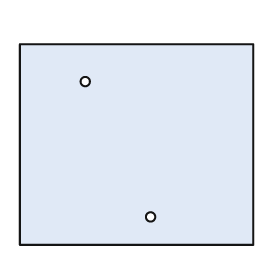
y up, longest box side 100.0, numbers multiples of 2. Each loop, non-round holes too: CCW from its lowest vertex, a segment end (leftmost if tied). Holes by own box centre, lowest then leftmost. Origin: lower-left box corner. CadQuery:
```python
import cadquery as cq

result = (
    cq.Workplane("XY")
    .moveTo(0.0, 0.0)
    .lineTo(100.0, 0.0)
    .lineTo(100.0, 86.0)
    .lineTo(0.0, 86.0)
    .close()
    .moveTo(56.0, 12.0)
    .circle(2.0)
    .moveTo(28.0, 70.0)
    .circle(2.0)
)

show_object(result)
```